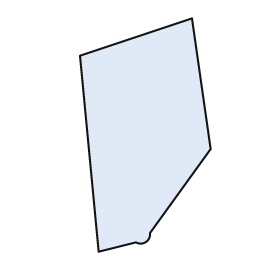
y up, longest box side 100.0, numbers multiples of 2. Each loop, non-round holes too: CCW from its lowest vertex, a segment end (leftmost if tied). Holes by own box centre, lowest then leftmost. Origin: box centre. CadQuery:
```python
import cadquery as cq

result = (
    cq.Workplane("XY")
    .moveTo(-20.0, -50.0)
    .lineTo(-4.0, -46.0)
    .threePointArc((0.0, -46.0), (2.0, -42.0))
    .lineTo(28.0, -6.0)
    .lineTo(20.0, 50.0)
    .lineTo(-28.0, 34.0)
    .close()
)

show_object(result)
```